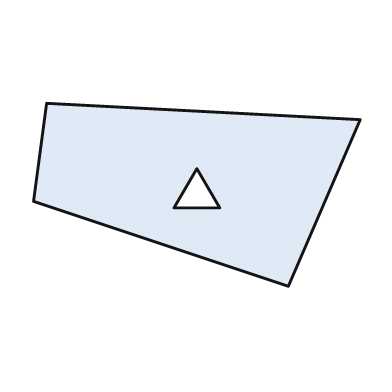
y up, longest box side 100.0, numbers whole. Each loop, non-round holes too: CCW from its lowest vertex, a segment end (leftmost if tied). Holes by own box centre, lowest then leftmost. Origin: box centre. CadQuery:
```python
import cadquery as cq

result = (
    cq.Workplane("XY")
    .moveTo(28.0, -28.0)
    .lineTo(50.0, 23.0)
    .lineTo(-46.0, 28.0)
    .lineTo(-50.0, -2.0)
    .close()
    .moveTo(-7.0, -4.0)
    .lineTo(7.0, -4.0)
    .lineTo(0.0, 8.0)
    .close()
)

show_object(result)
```